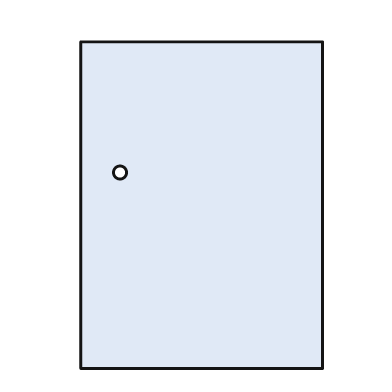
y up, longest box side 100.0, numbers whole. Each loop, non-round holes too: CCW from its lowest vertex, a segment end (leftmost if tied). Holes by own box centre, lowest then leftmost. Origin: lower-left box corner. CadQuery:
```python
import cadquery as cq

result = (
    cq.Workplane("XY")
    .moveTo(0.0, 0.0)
    .lineTo(74.0, 0.0)
    .lineTo(74.0, 100.0)
    .lineTo(0.0, 100.0)
    .close()
    .moveTo(12.0, 60.0)
    .circle(2.0)
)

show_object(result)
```